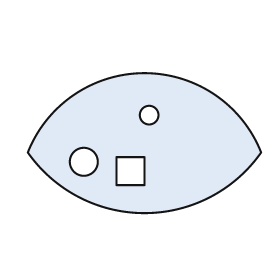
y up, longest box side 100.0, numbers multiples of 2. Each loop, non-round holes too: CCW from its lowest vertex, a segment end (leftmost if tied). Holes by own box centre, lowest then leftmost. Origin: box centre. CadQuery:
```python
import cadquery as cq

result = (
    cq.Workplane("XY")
    .moveTo(-50.0, -4.0)
    .threePointArc((0.0, -30.0), (50.0, -4.0))
    .threePointArc((0.0, 30.0), (-50.0, -4.0))
    .close()
    .moveTo(-12.0, -18.0)
    .lineTo(0.0, -18.0)
    .lineTo(0.0, -6.0)
    .lineTo(-12.0, -6.0)
    .close()
    .moveTo(-26.0, -8.0)
    .circle(6.0)
    .moveTo(2.0, 12.0)
    .circle(4.0)
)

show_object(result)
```